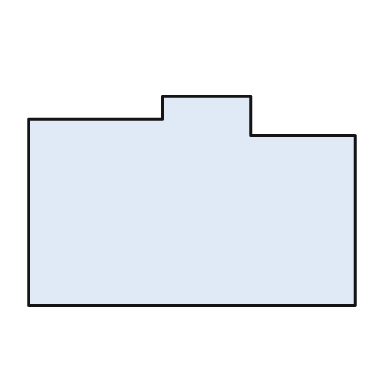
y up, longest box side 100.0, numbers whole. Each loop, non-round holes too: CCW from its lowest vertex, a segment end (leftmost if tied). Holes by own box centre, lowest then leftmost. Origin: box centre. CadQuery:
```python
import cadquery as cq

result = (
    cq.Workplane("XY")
    .moveTo(-50.0, -32.0)
    .lineTo(50.0, -32.0)
    .lineTo(50.0, 20.0)
    .lineTo(18.0, 20.0)
    .lineTo(18.0, 32.0)
    .lineTo(-9.0, 32.0)
    .lineTo(-9.0, 25.0)
    .lineTo(-50.0, 25.0)
    .close()
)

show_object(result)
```